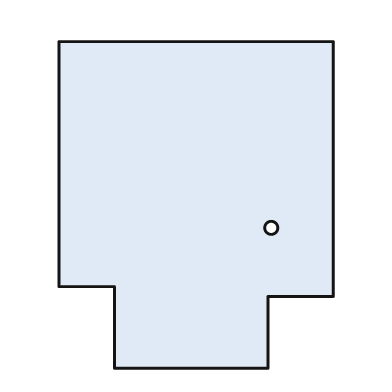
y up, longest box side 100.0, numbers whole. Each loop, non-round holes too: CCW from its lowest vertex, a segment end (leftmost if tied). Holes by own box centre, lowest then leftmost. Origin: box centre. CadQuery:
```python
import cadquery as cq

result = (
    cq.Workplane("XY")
    .moveTo(-25.0, -50.0)
    .lineTo(22.0, -50.0)
    .lineTo(22.0, -28.0)
    .lineTo(42.0, -28.0)
    .lineTo(42.0, 50.0)
    .lineTo(-42.0, 50.0)
    .lineTo(-42.0, -25.0)
    .lineTo(-25.0, -25.0)
    .close()
    .moveTo(23.0, -7.0)
    .circle(2.0)
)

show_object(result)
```